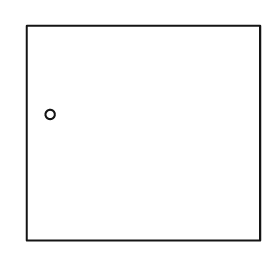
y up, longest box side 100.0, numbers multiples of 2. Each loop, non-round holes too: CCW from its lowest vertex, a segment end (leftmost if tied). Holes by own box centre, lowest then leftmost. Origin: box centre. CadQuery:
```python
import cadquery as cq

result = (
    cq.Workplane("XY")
    .moveTo(-50.0, -46.0)
    .lineTo(50.0, -46.0)
    .lineTo(50.0, 46.0)
    .lineTo(-50.0, 46.0)
    .close()
    .moveTo(-40.0, 8.0)
    .circle(2.0)
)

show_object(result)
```